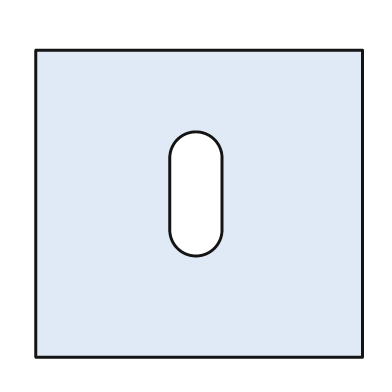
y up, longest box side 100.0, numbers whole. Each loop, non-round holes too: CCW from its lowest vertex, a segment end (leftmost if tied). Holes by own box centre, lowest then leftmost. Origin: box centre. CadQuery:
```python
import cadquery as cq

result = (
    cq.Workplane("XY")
    .moveTo(-50.0, -47.0)
    .lineTo(50.0, -47.0)
    .lineTo(50.0, 47.0)
    .lineTo(-50.0, 47.0)
    .close()
    .moveTo(-9.0, -8.0)
    .threePointArc((-1.0, -16.0), (7.0, -8.0))
    .lineTo(7.0, 14.0)
    .threePointArc((-1.0, 22.0), (-9.0, 14.0))
    .close()
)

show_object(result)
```